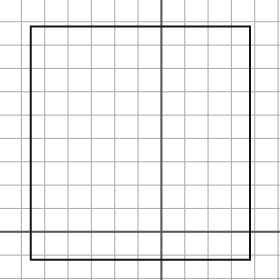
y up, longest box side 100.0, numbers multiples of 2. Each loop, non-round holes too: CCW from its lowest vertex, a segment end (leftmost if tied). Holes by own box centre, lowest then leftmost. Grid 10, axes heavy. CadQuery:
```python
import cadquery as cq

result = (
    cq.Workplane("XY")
    .moveTo(-56.0, -12.0)
    .lineTo(38.0, -12.0)
    .lineTo(38.0, 88.0)
    .lineTo(-56.0, 88.0)
    .close()
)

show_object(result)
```